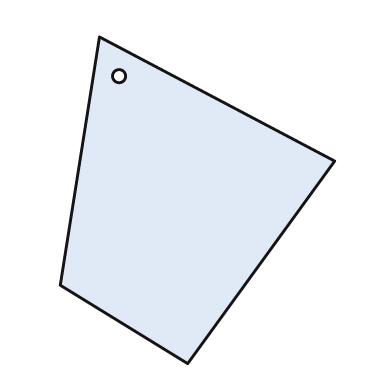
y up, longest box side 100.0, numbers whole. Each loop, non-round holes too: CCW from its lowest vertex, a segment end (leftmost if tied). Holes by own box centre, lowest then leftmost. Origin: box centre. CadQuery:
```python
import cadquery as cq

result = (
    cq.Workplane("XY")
    .moveTo(-3.0, -50.0)
    .lineTo(42.0, 12.0)
    .lineTo(-30.0, 50.0)
    .lineTo(-42.0, -26.0)
    .close()
    .moveTo(-24.0, 38.0)
    .circle(2.0)
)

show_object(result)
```